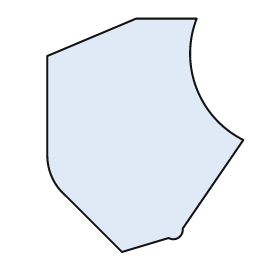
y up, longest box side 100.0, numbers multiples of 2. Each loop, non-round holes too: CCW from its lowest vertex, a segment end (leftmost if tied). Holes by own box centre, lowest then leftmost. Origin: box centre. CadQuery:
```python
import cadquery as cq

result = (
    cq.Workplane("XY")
    .moveTo(-10.0, -50.0)
    .lineTo(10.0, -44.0)
    .threePointArc((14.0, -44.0), (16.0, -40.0))
    .lineTo(42.0, -2.0)
    .threePointArc((22.0, 20.0), (22.0, 50.0))
    .lineTo(-4.0, 50.0)
    .lineTo(-42.0, 34.0)
    .lineTo(-42.0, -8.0)
    .threePointArc((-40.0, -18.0), (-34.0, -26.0))
    .close()
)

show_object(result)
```